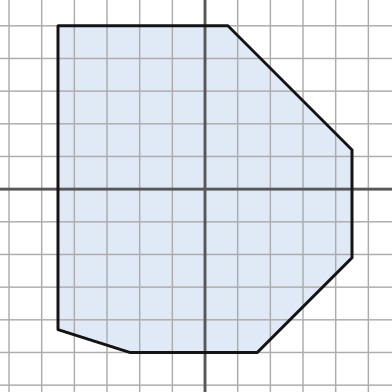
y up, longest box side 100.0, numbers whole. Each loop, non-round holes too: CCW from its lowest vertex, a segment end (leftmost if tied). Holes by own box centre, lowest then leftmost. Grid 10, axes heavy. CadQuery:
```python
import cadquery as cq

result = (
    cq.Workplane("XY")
    .moveTo(-23.0, -50.0)
    .lineTo(16.0, -50.0)
    .lineTo(45.0, -21.0)
    .lineTo(45.0, 12.0)
    .lineTo(7.0, 50.0)
    .lineTo(-45.0, 50.0)
    .lineTo(-45.0, -43.0)
    .close()
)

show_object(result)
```